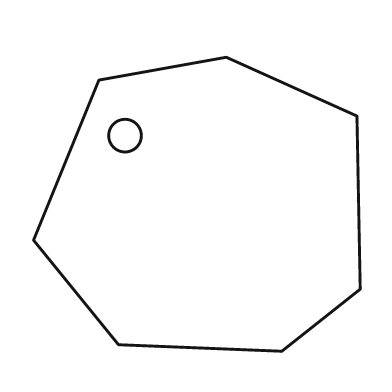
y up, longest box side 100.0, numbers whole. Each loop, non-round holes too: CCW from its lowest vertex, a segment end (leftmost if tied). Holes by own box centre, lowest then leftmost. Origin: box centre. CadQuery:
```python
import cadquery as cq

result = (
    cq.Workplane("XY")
    .moveTo(26.0, -45.0)
    .lineTo(50.0, -26.0)
    .lineTo(49.0, 27.0)
    .lineTo(9.0, 45.0)
    .lineTo(-30.0, 38.0)
    .lineTo(-50.0, -11.0)
    .lineTo(-24.0, -43.0)
    .close()
    .moveTo(-22.0, 21.0)
    .circle(5.0)
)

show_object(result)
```